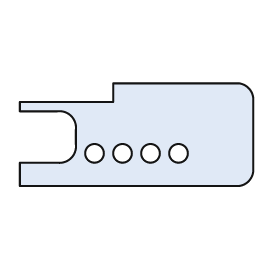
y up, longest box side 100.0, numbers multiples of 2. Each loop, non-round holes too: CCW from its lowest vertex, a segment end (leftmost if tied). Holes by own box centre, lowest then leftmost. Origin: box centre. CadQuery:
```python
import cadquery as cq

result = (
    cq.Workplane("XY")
    .moveTo(-50.0, -22.0)
    .lineTo(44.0, -22.0)
    .threePointArc((48.0, -20.0), (50.0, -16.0))
    .lineTo(50.0, 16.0)
    .threePointArc((48.0, 20.0), (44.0, 22.0))
    .lineTo(-10.0, 22.0)
    .lineTo(-10.0, 14.0)
    .lineTo(-50.0, 14.0)
    .lineTo(-50.0, 10.0)
    .lineTo(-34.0, 10.0)
    .threePointArc((-28.0, 8.0), (-26.0, 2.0))
    .lineTo(-26.0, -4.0)
    .threePointArc((-28.0, -10.0), (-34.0, -12.0))
    .lineTo(-50.0, -12.0)
    .close()
    .moveTo(-18.0, -8.0)
    .circle(4.0)
    .moveTo(-6.0, -8.0)
    .circle(4.0)
    .moveTo(6.0, -8.0)
    .circle(4.0)
    .moveTo(18.0, -8.0)
    .circle(4.0)
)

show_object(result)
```